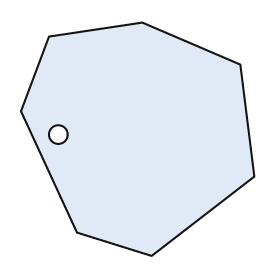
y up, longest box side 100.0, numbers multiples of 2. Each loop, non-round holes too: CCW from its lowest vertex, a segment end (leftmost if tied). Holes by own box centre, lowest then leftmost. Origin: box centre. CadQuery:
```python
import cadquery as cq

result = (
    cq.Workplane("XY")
    .moveTo(6.0, -50.0)
    .lineTo(50.0, -16.0)
    .lineTo(44.0, 32.0)
    .lineTo(2.0, 50.0)
    .lineTo(-38.0, 44.0)
    .lineTo(-50.0, 12.0)
    .lineTo(-26.0, -40.0)
    .close()
    .moveTo(-34.0, 2.0)
    .circle(4.0)
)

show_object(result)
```